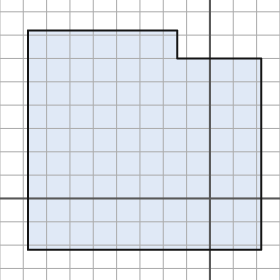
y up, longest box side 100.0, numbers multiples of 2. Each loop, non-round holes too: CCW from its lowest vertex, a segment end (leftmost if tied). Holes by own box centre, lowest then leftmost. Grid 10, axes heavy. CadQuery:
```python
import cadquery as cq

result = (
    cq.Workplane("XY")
    .moveTo(-78.0, -22.0)
    .lineTo(22.0, -22.0)
    .lineTo(22.0, 60.0)
    .lineTo(-14.0, 60.0)
    .lineTo(-14.0, 72.0)
    .lineTo(-78.0, 72.0)
    .close()
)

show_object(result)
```